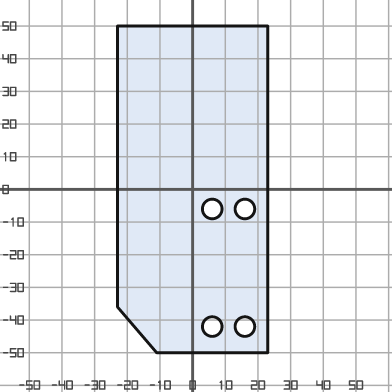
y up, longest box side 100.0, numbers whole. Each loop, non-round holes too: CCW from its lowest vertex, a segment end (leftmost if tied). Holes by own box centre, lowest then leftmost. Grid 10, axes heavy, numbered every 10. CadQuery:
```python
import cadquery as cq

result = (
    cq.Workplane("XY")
    .moveTo(-11.0, -50.0)
    .lineTo(23.0, -50.0)
    .lineTo(23.0, 50.0)
    .lineTo(-23.0, 50.0)
    .lineTo(-23.0, -36.0)
    .close()
    .moveTo(6.0, -42.0)
    .circle(3.0)
    .moveTo(16.0, -42.0)
    .circle(3.0)
    .moveTo(6.0, -6.0)
    .circle(3.0)
    .moveTo(16.0, -6.0)
    .circle(3.0)
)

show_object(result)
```